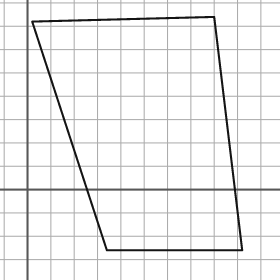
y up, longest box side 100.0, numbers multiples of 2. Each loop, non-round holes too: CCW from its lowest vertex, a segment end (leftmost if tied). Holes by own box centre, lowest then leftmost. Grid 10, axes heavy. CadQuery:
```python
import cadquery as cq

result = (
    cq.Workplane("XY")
    .moveTo(34.0, -26.0)
    .lineTo(92.0, -26.0)
    .lineTo(80.0, 74.0)
    .lineTo(2.0, 72.0)
    .close()
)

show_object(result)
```